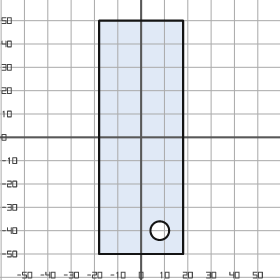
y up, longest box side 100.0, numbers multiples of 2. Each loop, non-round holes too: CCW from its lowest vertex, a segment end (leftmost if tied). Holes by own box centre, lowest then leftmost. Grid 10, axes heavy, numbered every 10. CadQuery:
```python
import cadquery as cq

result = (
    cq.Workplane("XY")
    .moveTo(-18.0, -50.0)
    .lineTo(18.0, -50.0)
    .lineTo(18.0, 50.0)
    .lineTo(-18.0, 50.0)
    .close()
    .moveTo(8.0, -40.0)
    .circle(4.0)
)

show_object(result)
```